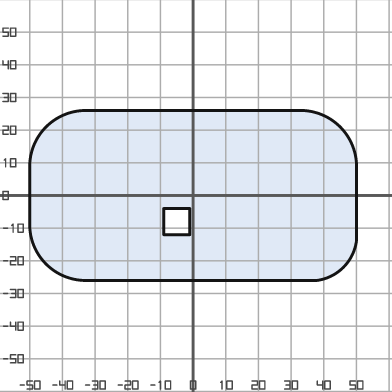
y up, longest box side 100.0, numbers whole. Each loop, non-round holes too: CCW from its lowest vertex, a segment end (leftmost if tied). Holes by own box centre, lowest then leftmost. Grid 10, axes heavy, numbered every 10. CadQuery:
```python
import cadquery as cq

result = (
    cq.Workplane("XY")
    .moveTo(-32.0, -26.0)
    .lineTo(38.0, -26.0)
    .threePointArc((46.0, -22.0), (50.0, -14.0))
    .lineTo(50.0, 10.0)
    .threePointArc((45.0, 21.0), (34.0, 26.0))
    .lineTo(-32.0, 26.0)
    .threePointArc((-45.0, 21.0), (-50.0, 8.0))
    .lineTo(-50.0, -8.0)
    .threePointArc((-45.0, -21.0), (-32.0, -26.0))
    .close()
    .moveTo(-9.0, -12.0)
    .lineTo(-1.0, -12.0)
    .lineTo(-1.0, -4.0)
    .lineTo(-9.0, -4.0)
    .close()
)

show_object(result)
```